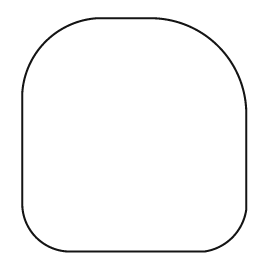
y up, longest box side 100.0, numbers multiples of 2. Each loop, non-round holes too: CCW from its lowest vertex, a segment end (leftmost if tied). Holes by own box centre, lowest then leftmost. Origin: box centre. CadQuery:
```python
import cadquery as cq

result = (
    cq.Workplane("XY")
    .moveTo(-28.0, -50.0)
    .lineTo(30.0, -50.0)
    .threePointArc((42.0, -44.0), (48.0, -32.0))
    .lineTo(48.0, 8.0)
    .threePointArc((36.0, 38.0), (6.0, 50.0))
    .lineTo(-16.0, 50.0)
    .threePointArc((-38.0, 40.0), (-48.0, 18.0))
    .lineTo(-48.0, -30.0)
    .threePointArc((-42.0, -44.0), (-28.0, -50.0))
    .close()
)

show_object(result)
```